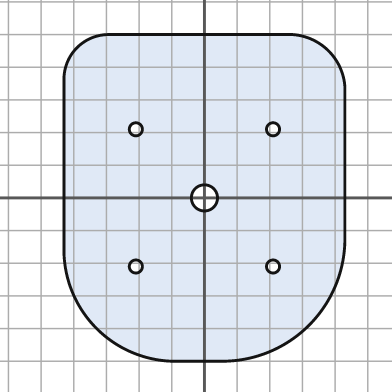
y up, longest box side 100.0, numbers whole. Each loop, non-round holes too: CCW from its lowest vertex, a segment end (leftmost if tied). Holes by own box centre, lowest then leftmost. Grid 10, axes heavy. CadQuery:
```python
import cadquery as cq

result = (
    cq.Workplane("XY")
    .moveTo(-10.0, -50.0)
    .lineTo(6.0, -50.0)
    .threePointArc((32.0, -39.0), (43.0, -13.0))
    .lineTo(43.0, 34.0)
    .threePointArc((38.0, 45.0), (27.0, 50.0))
    .lineTo(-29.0, 50.0)
    .threePointArc((-39.0, 46.0), (-43.0, 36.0))
    .lineTo(-43.0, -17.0)
    .threePointArc((-33.0, -40.0), (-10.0, -50.0))
    .close()
    .moveTo(-21.0, -21.0)
    .circle(2.0)
    .moveTo(21.0, -21.0)
    .circle(2.0)
    .moveTo(0.0, 0.0)
    .circle(4.0)
    .moveTo(-21.0, 21.0)
    .circle(2.0)
    .moveTo(21.0, 21.0)
    .circle(2.0)
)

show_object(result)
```